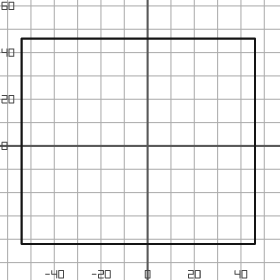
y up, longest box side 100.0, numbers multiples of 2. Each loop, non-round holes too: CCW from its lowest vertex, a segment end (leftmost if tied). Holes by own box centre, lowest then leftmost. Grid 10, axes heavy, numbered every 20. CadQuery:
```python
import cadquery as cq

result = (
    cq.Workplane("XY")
    .moveTo(-54.0, -42.0)
    .lineTo(46.0, -42.0)
    .lineTo(46.0, 46.0)
    .lineTo(-54.0, 46.0)
    .close()
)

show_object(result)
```